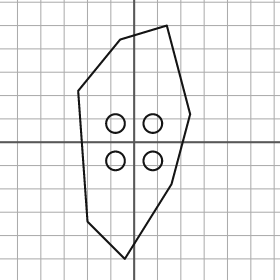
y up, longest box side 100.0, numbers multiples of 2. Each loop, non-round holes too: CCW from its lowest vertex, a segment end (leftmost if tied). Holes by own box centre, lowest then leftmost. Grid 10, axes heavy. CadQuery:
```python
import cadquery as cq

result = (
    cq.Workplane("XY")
    .moveTo(-4.0, -50.0)
    .lineTo(16.0, -18.0)
    .lineTo(24.0, 12.0)
    .lineTo(14.0, 50.0)
    .lineTo(-6.0, 44.0)
    .lineTo(-24.0, 22.0)
    .lineTo(-20.0, -34.0)
    .close()
    .moveTo(-8.0, -8.0)
    .circle(4.0)
    .moveTo(8.0, -8.0)
    .circle(4.0)
    .moveTo(-8.0, 8.0)
    .circle(4.0)
    .moveTo(8.0, 8.0)
    .circle(4.0)
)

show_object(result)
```